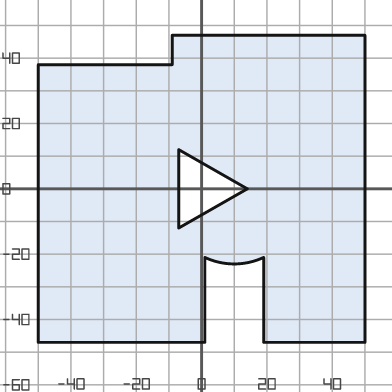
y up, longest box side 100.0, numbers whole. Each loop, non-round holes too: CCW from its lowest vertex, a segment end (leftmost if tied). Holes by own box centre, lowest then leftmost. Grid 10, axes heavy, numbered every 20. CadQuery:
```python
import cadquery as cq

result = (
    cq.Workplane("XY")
    .moveTo(-50.0, -47.0)
    .lineTo(1.0, -47.0)
    .lineTo(1.0, -21.0)
    .threePointArc((10.0, -23.0), (19.0, -21.0))
    .lineTo(19.0, -47.0)
    .lineTo(50.0, -47.0)
    .lineTo(50.0, 47.0)
    .lineTo(-9.0, 47.0)
    .lineTo(-9.0, 38.0)
    .lineTo(-50.0, 38.0)
    .close()
    .moveTo(-7.0, -12.0)
    .lineTo(14.0, 0.0)
    .lineTo(-7.0, 12.0)
    .close()
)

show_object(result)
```